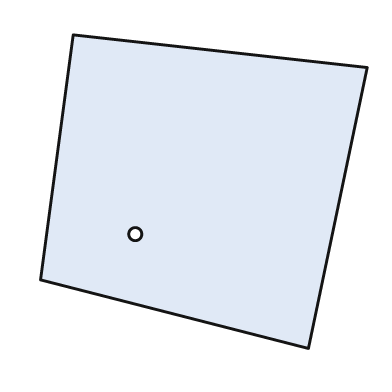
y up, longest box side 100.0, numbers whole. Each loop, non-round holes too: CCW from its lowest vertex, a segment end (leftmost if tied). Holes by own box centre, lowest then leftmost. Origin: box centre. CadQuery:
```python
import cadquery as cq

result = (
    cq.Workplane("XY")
    .moveTo(32.0, -48.0)
    .lineTo(50.0, 38.0)
    .lineTo(-40.0, 48.0)
    .lineTo(-50.0, -27.0)
    .close()
    .moveTo(-21.0, -13.0)
    .circle(2.0)
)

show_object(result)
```